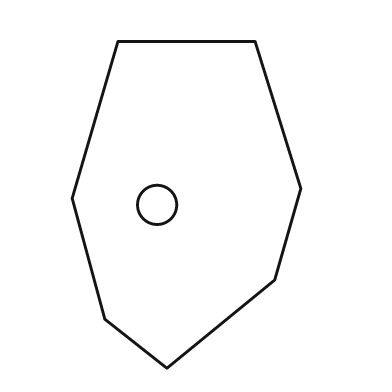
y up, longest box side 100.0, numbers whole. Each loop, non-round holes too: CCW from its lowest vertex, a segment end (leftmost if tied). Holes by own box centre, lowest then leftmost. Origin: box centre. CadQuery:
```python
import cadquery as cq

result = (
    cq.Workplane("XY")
    .moveTo(-6.0, -50.0)
    .lineTo(27.0, -23.0)
    .lineTo(35.0, 5.0)
    .lineTo(21.0, 50.0)
    .lineTo(-21.0, 50.0)
    .lineTo(-35.0, 2.0)
    .lineTo(-25.0, -35.0)
    .close()
    .moveTo(-9.0, 0.0)
    .circle(6.0)
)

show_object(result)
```